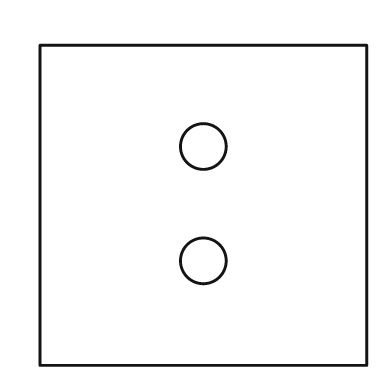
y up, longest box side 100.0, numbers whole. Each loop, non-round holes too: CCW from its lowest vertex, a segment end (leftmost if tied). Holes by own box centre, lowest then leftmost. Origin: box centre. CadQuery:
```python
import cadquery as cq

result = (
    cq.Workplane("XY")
    .moveTo(-50.0, -49.0)
    .lineTo(50.0, -49.0)
    .lineTo(50.0, 49.0)
    .lineTo(-50.0, 49.0)
    .close()
    .moveTo(0.0, -17.0)
    .circle(7.0)
    .moveTo(0.0, 18.0)
    .circle(7.0)
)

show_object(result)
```